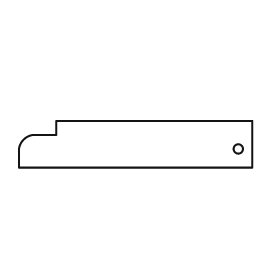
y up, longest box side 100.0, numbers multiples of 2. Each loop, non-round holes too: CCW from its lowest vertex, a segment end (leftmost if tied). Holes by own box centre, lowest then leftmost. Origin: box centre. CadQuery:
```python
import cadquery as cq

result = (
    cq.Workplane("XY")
    .moveTo(-50.0, -10.0)
    .lineTo(50.0, -10.0)
    .lineTo(50.0, 10.0)
    .lineTo(-34.0, 10.0)
    .lineTo(-34.0, 4.0)
    .lineTo(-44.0, 4.0)
    .threePointArc((-48.0, 2.0), (-50.0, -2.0))
    .close()
    .moveTo(44.0, -2.0)
    .circle(2.0)
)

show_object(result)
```